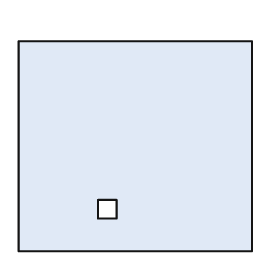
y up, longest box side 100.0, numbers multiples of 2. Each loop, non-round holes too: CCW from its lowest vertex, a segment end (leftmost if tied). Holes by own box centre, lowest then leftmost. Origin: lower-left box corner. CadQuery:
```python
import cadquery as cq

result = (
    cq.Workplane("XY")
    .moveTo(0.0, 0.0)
    .lineTo(100.0, 0.0)
    .lineTo(100.0, 90.0)
    .lineTo(0.0, 90.0)
    .close()
    .moveTo(34.0, 14.0)
    .lineTo(42.0, 14.0)
    .lineTo(42.0, 22.0)
    .lineTo(34.0, 22.0)
    .close()
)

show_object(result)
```